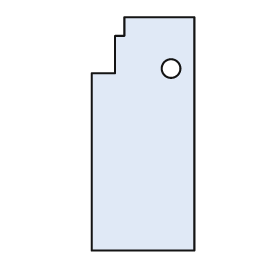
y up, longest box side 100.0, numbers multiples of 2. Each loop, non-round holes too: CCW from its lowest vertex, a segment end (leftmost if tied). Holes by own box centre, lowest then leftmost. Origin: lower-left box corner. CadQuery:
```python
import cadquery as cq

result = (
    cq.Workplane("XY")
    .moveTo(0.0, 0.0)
    .lineTo(44.0, 0.0)
    .lineTo(44.0, 100.0)
    .lineTo(14.0, 100.0)
    .lineTo(14.0, 92.0)
    .lineTo(10.0, 92.0)
    .lineTo(10.0, 76.0)
    .lineTo(0.0, 76.0)
    .close()
    .moveTo(34.0, 78.0)
    .circle(4.0)
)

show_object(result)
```